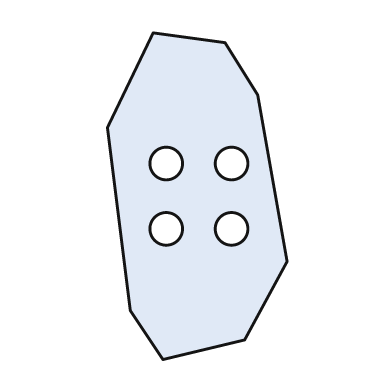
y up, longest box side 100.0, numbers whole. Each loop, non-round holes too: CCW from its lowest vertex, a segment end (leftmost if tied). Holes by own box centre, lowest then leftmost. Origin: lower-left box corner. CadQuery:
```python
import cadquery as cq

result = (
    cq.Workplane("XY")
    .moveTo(17.0, 0.0)
    .lineTo(42.0, 6.0)
    .lineTo(55.0, 30.0)
    .lineTo(46.0, 81.0)
    .lineTo(36.0, 97.0)
    .lineTo(14.0, 100.0)
    .lineTo(0.0, 71.0)
    .lineTo(7.0, 15.0)
    .close()
    .moveTo(18.0, 40.0)
    .circle(5.0)
    .moveTo(38.0, 40.0)
    .circle(5.0)
    .moveTo(18.0, 60.0)
    .circle(5.0)
    .moveTo(38.0, 60.0)
    .circle(5.0)
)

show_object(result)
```